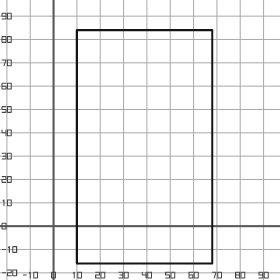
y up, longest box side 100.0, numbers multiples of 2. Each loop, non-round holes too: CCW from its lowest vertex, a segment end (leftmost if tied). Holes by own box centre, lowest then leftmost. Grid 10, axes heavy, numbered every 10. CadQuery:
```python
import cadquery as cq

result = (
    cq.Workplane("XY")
    .moveTo(10.0, -16.0)
    .lineTo(68.0, -16.0)
    .lineTo(68.0, 84.0)
    .lineTo(10.0, 84.0)
    .close()
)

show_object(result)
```